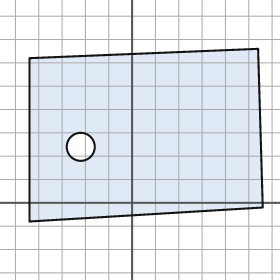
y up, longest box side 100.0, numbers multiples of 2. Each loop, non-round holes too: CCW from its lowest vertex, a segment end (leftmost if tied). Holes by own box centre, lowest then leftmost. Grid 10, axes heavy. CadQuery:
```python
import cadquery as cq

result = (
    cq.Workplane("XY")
    .moveTo(-44.0, -8.0)
    .lineTo(56.0, -2.0)
    .lineTo(54.0, 66.0)
    .lineTo(-44.0, 62.0)
    .close()
    .moveTo(-22.0, 24.0)
    .circle(6.0)
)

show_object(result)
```